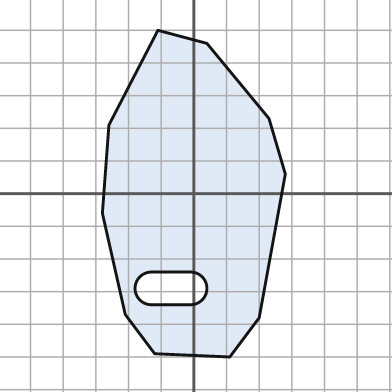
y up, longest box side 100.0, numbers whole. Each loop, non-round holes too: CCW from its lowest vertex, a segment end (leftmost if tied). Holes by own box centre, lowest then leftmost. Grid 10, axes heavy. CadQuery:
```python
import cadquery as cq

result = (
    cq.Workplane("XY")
    .moveTo(11.0, -50.0)
    .lineTo(20.0, -38.0)
    .lineTo(28.0, 6.0)
    .lineTo(23.0, 23.0)
    .lineTo(4.0, 46.0)
    .lineTo(-11.0, 50.0)
    .lineTo(-26.0, 21.0)
    .lineTo(-28.0, -6.0)
    .lineTo(-21.0, -37.0)
    .lineTo(-12.0, -49.0)
    .close()
    .moveTo(-13.0, -34.0)
    .lineTo(-1.0, -34.0)
    .threePointArc((4.0, -29.0), (-1.0, -24.0))
    .lineTo(-13.0, -24.0)
    .threePointArc((-18.0, -29.0), (-13.0, -34.0))
    .close()
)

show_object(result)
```